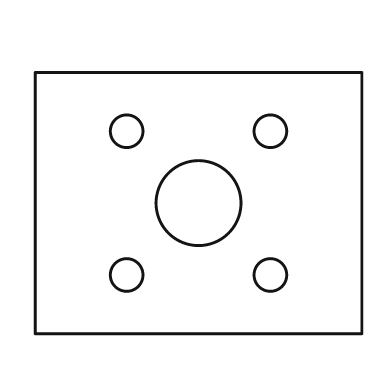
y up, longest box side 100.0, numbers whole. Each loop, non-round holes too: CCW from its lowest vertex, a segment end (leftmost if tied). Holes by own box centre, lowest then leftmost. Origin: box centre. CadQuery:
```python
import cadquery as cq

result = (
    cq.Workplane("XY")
    .moveTo(-50.0, -40.0)
    .lineTo(50.0, -40.0)
    .lineTo(50.0, 40.0)
    .lineTo(-50.0, 40.0)
    .close()
    .moveTo(-22.0, -22.0)
    .circle(5.0)
    .moveTo(22.0, -22.0)
    .circle(5.0)
    .moveTo(0.0, 0.0)
    .circle(13.0)
    .moveTo(-22.0, 22.0)
    .circle(5.0)
    .moveTo(22.0, 22.0)
    .circle(5.0)
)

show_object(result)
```